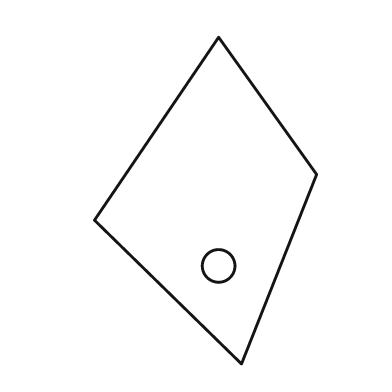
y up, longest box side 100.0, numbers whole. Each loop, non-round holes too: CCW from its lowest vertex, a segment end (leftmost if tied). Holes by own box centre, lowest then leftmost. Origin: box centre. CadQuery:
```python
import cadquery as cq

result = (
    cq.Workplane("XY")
    .moveTo(11.0, -50.0)
    .lineTo(34.0, 8.0)
    .lineTo(4.0, 50.0)
    .lineTo(-34.0, -6.0)
    .close()
    .moveTo(4.0, -20.0)
    .circle(5.0)
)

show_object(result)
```